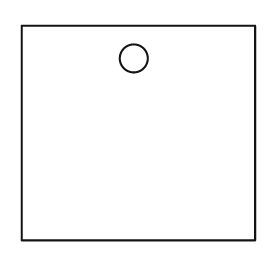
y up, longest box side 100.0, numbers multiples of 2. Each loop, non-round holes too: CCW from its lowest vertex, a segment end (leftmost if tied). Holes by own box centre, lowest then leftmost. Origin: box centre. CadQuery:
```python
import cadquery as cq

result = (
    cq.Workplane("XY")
    .moveTo(-50.0, -46.0)
    .lineTo(50.0, -46.0)
    .lineTo(50.0, 46.0)
    .lineTo(-50.0, 46.0)
    .close()
    .moveTo(-2.0, 32.0)
    .circle(6.0)
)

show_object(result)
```